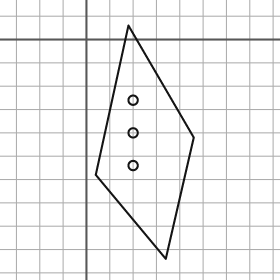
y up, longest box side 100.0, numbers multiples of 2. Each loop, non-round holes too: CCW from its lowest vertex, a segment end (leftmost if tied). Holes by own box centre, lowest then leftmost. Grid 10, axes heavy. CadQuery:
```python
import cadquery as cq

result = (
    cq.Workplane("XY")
    .moveTo(34.0, -94.0)
    .lineTo(46.0, -42.0)
    .lineTo(18.0, 6.0)
    .lineTo(4.0, -58.0)
    .close()
    .moveTo(20.0, -54.0)
    .circle(2.0)
    .moveTo(20.0, -40.0)
    .circle(2.0)
    .moveTo(20.0, -26.0)
    .circle(2.0)
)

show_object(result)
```